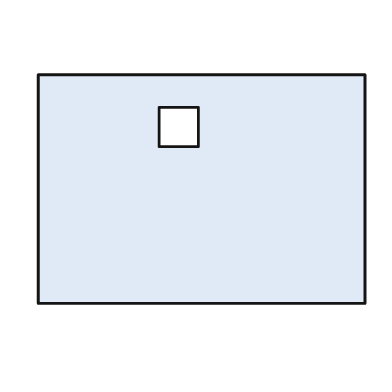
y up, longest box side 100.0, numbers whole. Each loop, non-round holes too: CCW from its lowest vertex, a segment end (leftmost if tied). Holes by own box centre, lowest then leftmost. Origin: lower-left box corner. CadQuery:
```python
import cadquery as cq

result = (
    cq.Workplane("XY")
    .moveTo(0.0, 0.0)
    .lineTo(100.0, 0.0)
    .lineTo(100.0, 70.0)
    .lineTo(0.0, 70.0)
    .close()
    .moveTo(37.0, 48.0)
    .lineTo(49.0, 48.0)
    .lineTo(49.0, 60.0)
    .lineTo(37.0, 60.0)
    .close()
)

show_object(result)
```